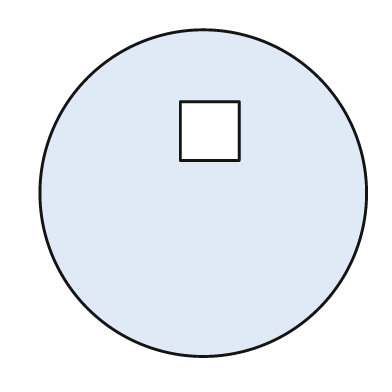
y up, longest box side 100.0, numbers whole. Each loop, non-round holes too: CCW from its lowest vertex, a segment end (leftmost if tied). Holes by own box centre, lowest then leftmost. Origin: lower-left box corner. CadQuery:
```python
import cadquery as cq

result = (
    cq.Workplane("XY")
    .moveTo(50.0, 50.0)
    .circle(50.0)
    .moveTo(43.0, 60.0)
    .lineTo(61.0, 60.0)
    .lineTo(61.0, 78.0)
    .lineTo(43.0, 78.0)
    .close()
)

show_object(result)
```